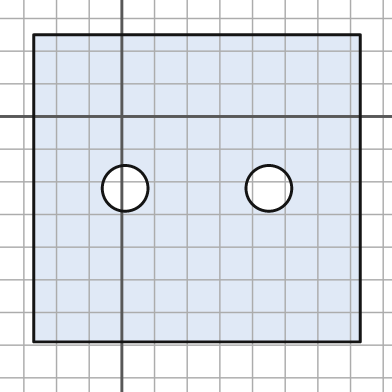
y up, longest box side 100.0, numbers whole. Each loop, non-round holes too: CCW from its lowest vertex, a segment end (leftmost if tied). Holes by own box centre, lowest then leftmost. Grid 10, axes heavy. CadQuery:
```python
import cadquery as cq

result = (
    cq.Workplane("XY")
    .moveTo(-27.0, -69.0)
    .lineTo(73.0, -69.0)
    .lineTo(73.0, 25.0)
    .lineTo(-27.0, 25.0)
    .close()
    .moveTo(1.0, -22.0)
    .circle(7.0)
    .moveTo(45.0, -22.0)
    .circle(7.0)
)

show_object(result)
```